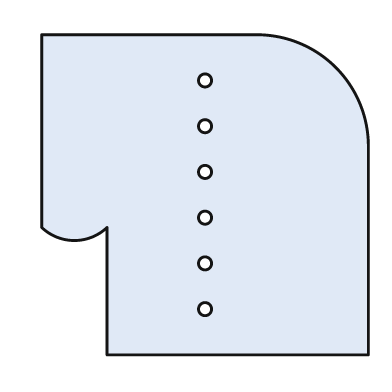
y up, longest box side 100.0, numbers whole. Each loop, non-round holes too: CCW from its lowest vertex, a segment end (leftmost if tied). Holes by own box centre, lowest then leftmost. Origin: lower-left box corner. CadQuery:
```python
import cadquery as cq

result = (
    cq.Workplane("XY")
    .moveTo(20.0, 0.0)
    .lineTo(100.0, 0.0)
    .lineTo(100.0, 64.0)
    .threePointArc((90.0, 88.0), (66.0, 98.0))
    .lineTo(0.0, 98.0)
    .lineTo(0.0, 39.0)
    .threePointArc((10.0, 35.0), (20.0, 39.0))
    .close()
    .moveTo(50.0, 14.0)
    .circle(2.0)
    .moveTo(50.0, 28.0)
    .circle(2.0)
    .moveTo(50.0, 42.0)
    .circle(2.0)
    .moveTo(50.0, 56.0)
    .circle(2.0)
    .moveTo(50.0, 70.0)
    .circle(2.0)
    .moveTo(50.0, 84.0)
    .circle(2.0)
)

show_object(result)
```